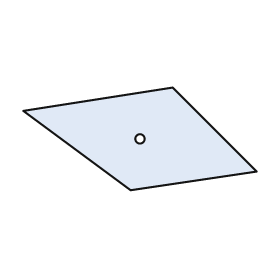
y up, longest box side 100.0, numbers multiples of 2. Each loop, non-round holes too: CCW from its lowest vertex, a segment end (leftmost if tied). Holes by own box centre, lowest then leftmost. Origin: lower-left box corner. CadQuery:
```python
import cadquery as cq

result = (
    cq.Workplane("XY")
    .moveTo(46.0, 0.0)
    .lineTo(100.0, 8.0)
    .lineTo(64.0, 44.0)
    .lineTo(0.0, 34.0)
    .close()
    .moveTo(50.0, 22.0)
    .circle(2.0)
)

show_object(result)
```